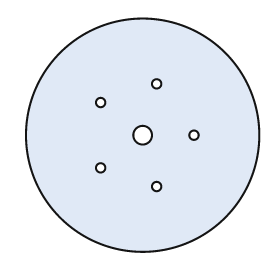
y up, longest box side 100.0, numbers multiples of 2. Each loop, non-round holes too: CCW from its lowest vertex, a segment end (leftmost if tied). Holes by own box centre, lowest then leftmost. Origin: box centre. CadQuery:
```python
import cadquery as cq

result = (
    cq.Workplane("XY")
    .moveTo(0.0, 0.0)
    .circle(50.0)
    .moveTo(6.0, -22.0)
    .circle(2.0)
    .moveTo(-18.0, -14.0)
    .circle(2.0)
    .moveTo(0.0, 0.0)
    .circle(4.0)
    .moveTo(22.0, 0.0)
    .circle(2.0)
    .moveTo(-18.0, 14.0)
    .circle(2.0)
    .moveTo(6.0, 22.0)
    .circle(2.0)
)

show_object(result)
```